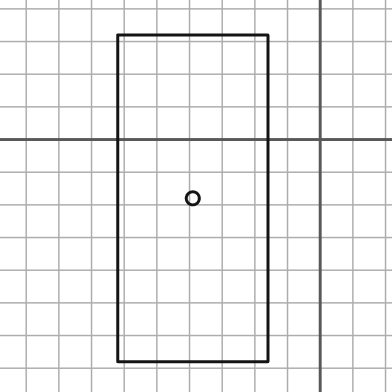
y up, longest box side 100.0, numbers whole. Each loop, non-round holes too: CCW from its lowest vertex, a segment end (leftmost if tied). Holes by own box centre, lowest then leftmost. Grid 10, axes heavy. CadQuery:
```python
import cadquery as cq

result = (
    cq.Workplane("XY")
    .moveTo(-62.0, -68.0)
    .lineTo(-16.0, -68.0)
    .lineTo(-16.0, 32.0)
    .lineTo(-62.0, 32.0)
    .close()
    .moveTo(-39.0, -18.0)
    .circle(2.0)
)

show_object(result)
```